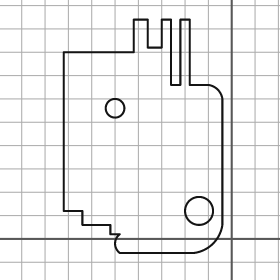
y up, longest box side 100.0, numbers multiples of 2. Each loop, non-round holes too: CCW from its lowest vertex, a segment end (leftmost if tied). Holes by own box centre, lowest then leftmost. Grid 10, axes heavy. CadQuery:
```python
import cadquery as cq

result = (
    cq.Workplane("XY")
    .moveTo(-48.0, -6.0)
    .lineTo(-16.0, -6.0)
    .threePointArc((-8.0, -2.0), (-4.0, 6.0))
    .lineTo(-4.0, 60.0)
    .threePointArc((-6.0, 64.0), (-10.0, 66.0))
    .lineTo(-18.0, 66.0)
    .lineTo(-18.0, 94.0)
    .lineTo(-22.0, 94.0)
    .lineTo(-22.0, 66.0)
    .lineTo(-26.0, 66.0)
    .lineTo(-26.0, 94.0)
    .lineTo(-30.0, 94.0)
    .lineTo(-30.0, 82.0)
    .lineTo(-36.0, 82.0)
    .lineTo(-36.0, 94.0)
    .lineTo(-42.0, 94.0)
    .lineTo(-42.0, 80.0)
    .lineTo(-72.0, 80.0)
    .lineTo(-72.0, 12.0)
    .lineTo(-64.0, 12.0)
    .lineTo(-64.0, 6.0)
    .lineTo(-52.0, 6.0)
    .lineTo(-52.0, 2.0)
    .lineTo(-48.0, 2.0)
    .threePointArc((-50.0, -2.0), (-48.0, -6.0))
    .close()
    .moveTo(-14.0, 12.0)
    .circle(6.0)
    .moveTo(-50.0, 56.0)
    .circle(4.0)
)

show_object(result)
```